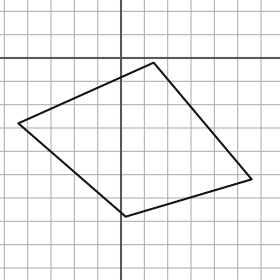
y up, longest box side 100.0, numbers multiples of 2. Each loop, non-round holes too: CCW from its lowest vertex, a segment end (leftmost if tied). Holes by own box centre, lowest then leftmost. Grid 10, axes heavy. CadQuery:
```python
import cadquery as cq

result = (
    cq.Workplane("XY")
    .moveTo(2.0, -68.0)
    .lineTo(56.0, -52.0)
    .lineTo(14.0, -2.0)
    .lineTo(-44.0, -28.0)
    .close()
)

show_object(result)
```